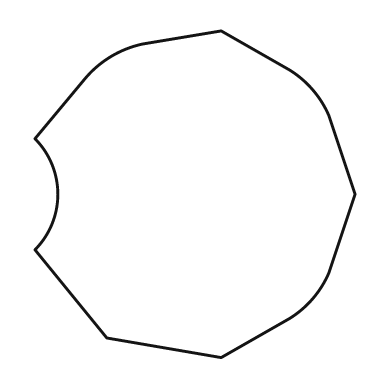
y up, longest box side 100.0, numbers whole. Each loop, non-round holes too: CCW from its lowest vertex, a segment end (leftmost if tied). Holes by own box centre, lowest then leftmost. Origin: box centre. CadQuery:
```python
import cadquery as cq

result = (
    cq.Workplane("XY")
    .moveTo(8.0, -50.0)
    .lineTo(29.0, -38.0)
    .threePointArc((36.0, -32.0), (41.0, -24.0))
    .lineTo(49.0, 0.0)
    .lineTo(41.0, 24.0)
    .threePointArc((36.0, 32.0), (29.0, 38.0))
    .lineTo(8.0, 50.0)
    .lineTo(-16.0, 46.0)
    .threePointArc((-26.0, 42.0), (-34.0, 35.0))
    .lineTo(-49.0, 17.0)
    .threePointArc((-42.0, 0.0), (-49.0, -17.0))
    .lineTo(-27.0, -44.0)
    .close()
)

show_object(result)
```